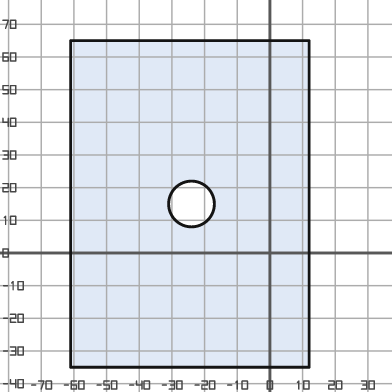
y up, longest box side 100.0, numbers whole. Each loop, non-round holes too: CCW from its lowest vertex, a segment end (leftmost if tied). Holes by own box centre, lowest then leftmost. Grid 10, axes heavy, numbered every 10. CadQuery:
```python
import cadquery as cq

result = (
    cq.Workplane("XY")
    .moveTo(-61.0, -35.0)
    .lineTo(12.0, -35.0)
    .lineTo(12.0, 65.0)
    .lineTo(-61.0, 65.0)
    .close()
    .moveTo(-24.0, 15.0)
    .circle(7.0)
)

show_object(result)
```